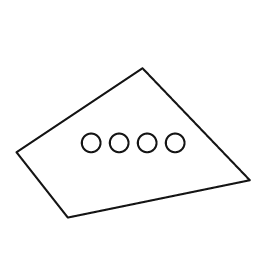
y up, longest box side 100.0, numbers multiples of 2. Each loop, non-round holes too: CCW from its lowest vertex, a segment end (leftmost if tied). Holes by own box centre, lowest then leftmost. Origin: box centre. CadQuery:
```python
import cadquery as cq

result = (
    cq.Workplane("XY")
    .moveTo(-28.0, -32.0)
    .lineTo(50.0, -16.0)
    .lineTo(4.0, 32.0)
    .lineTo(-50.0, -4.0)
    .close()
    .moveTo(-18.0, 0.0)
    .circle(4.0)
    .moveTo(-6.0, 0.0)
    .circle(4.0)
    .moveTo(6.0, 0.0)
    .circle(4.0)
    .moveTo(18.0, 0.0)
    .circle(4.0)
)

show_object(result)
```